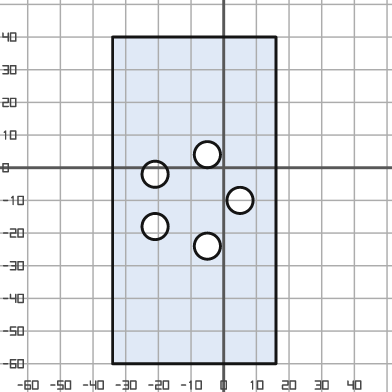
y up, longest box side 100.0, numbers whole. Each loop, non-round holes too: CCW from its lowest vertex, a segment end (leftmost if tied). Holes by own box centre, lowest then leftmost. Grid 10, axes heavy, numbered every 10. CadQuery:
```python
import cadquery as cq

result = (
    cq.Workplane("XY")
    .moveTo(-34.0, -60.0)
    .lineTo(16.0, -60.0)
    .lineTo(16.0, 40.0)
    .lineTo(-34.0, 40.0)
    .close()
    .moveTo(-5.0, -24.0)
    .circle(4.0)
    .moveTo(-21.0, -18.0)
    .circle(4.0)
    .moveTo(5.0, -10.0)
    .circle(4.0)
    .moveTo(-21.0, -2.0)
    .circle(4.0)
    .moveTo(-5.0, 4.0)
    .circle(4.0)
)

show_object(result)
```